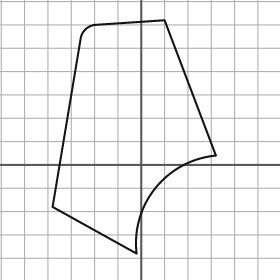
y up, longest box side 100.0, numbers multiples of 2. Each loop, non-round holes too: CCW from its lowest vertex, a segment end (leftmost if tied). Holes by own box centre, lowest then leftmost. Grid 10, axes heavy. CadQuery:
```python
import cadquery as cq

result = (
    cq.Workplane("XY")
    .moveTo(-2.0, -38.0)
    .threePointArc((6.0, -10.0), (32.0, 4.0))
    .lineTo(10.0, 62.0)
    .lineTo(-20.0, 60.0)
    .threePointArc((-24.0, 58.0), (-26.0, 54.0))
    .lineTo(-38.0, -18.0)
    .close()
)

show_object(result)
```